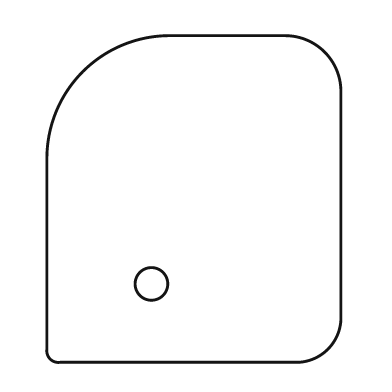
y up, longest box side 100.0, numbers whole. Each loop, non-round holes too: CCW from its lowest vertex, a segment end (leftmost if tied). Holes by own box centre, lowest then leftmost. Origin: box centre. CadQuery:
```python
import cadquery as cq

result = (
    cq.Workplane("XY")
    .moveTo(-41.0, -50.0)
    .lineTo(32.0, -50.0)
    .threePointArc((41.0, -46.0), (45.0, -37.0))
    .lineTo(45.0, 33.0)
    .threePointArc((40.0, 45.0), (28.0, 50.0))
    .lineTo(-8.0, 50.0)
    .threePointArc((-34.0, 39.0), (-45.0, 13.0))
    .lineTo(-45.0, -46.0)
    .threePointArc((-44.0, -49.0), (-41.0, -50.0))
    .close()
    .moveTo(-13.0, -26.0)
    .circle(5.0)
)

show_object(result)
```